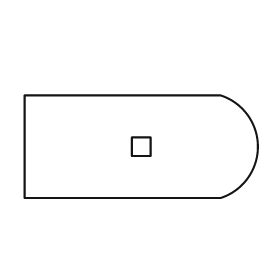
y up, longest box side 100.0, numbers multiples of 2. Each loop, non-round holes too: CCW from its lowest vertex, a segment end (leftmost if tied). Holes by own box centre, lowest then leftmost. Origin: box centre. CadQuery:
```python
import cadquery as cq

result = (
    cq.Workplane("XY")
    .moveTo(-50.0, -22.0)
    .lineTo(34.0, -22.0)
    .threePointArc((50.0, 0.0), (34.0, 22.0))
    .lineTo(-50.0, 22.0)
    .close()
    .moveTo(-4.0, -4.0)
    .lineTo(4.0, -4.0)
    .lineTo(4.0, 4.0)
    .lineTo(-4.0, 4.0)
    .close()
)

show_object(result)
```